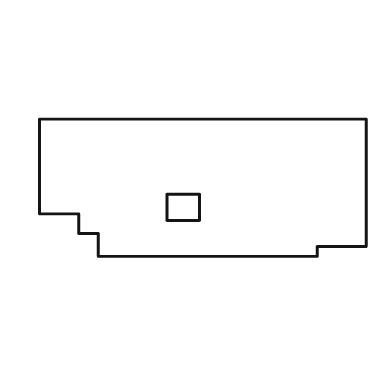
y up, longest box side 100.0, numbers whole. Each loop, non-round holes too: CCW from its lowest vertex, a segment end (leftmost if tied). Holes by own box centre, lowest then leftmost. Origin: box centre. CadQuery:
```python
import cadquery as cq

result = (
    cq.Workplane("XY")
    .moveTo(-32.0, -21.0)
    .lineTo(35.0, -21.0)
    .lineTo(35.0, -18.0)
    .lineTo(50.0, -18.0)
    .lineTo(50.0, 21.0)
    .lineTo(-50.0, 21.0)
    .lineTo(-50.0, -8.0)
    .lineTo(-38.0, -8.0)
    .lineTo(-38.0, -14.0)
    .lineTo(-32.0, -14.0)
    .close()
    .moveTo(-11.0, -10.0)
    .lineTo(-1.0, -10.0)
    .lineTo(-1.0, -2.0)
    .lineTo(-11.0, -2.0)
    .close()
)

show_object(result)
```